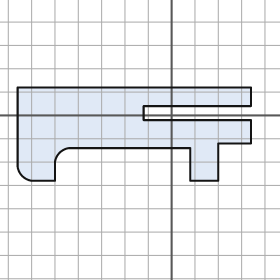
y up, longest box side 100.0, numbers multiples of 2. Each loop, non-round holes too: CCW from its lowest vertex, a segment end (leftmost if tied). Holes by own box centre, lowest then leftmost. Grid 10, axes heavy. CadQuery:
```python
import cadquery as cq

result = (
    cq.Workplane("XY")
    .moveTo(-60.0, -28.0)
    .lineTo(-50.0, -28.0)
    .lineTo(-50.0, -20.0)
    .threePointArc((-48.0, -16.0), (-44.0, -14.0))
    .lineTo(8.0, -14.0)
    .lineTo(8.0, -28.0)
    .lineTo(20.0, -28.0)
    .lineTo(20.0, -12.0)
    .lineTo(34.0, -12.0)
    .lineTo(34.0, -2.0)
    .lineTo(-12.0, -2.0)
    .lineTo(-12.0, 4.0)
    .lineTo(34.0, 4.0)
    .lineTo(34.0, 12.0)
    .lineTo(-66.0, 12.0)
    .lineTo(-66.0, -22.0)
    .threePointArc((-64.0, -26.0), (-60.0, -28.0))
    .close()
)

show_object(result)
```